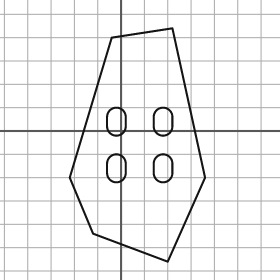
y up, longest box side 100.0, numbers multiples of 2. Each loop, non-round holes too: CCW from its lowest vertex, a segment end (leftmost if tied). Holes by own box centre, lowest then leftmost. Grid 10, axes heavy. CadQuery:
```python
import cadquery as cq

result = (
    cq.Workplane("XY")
    .moveTo(20.0, -56.0)
    .lineTo(36.0, -20.0)
    .lineTo(22.0, 44.0)
    .lineTo(-4.0, 40.0)
    .lineTo(-22.0, -20.0)
    .lineTo(-12.0, -44.0)
    .close()
    .moveTo(-6.0, -18.0)
    .threePointArc((-2.0, -22.0), (2.0, -18.0))
    .lineTo(2.0, -14.0)
    .threePointArc((-2.0, -10.0), (-6.0, -14.0))
    .close()
    .moveTo(14.0, -18.0)
    .threePointArc((18.0, -22.0), (22.0, -18.0))
    .lineTo(22.0, -14.0)
    .threePointArc((18.0, -10.0), (14.0, -14.0))
    .close()
    .moveTo(-6.0, 2.0)
    .threePointArc((-2.0, -2.0), (2.0, 2.0))
    .lineTo(2.0, 6.0)
    .threePointArc((-2.0, 10.0), (-6.0, 6.0))
    .close()
    .moveTo(14.0, 2.0)
    .threePointArc((18.0, -2.0), (22.0, 2.0))
    .lineTo(22.0, 6.0)
    .threePointArc((18.0, 10.0), (14.0, 6.0))
    .close()
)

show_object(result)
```